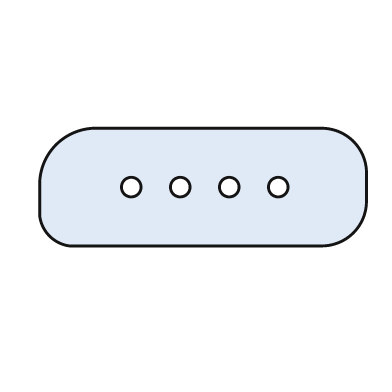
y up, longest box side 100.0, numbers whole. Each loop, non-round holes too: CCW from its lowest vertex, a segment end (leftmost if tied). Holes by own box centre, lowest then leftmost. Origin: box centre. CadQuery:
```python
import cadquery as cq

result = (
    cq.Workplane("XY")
    .moveTo(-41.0, -18.0)
    .lineTo(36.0, -18.0)
    .threePointArc((46.0, -14.0), (50.0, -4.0))
    .lineTo(50.0, 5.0)
    .threePointArc((46.0, 14.0), (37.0, 18.0))
    .lineTo(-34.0, 18.0)
    .threePointArc((-45.0, 13.0), (-50.0, 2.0))
    .lineTo(-50.0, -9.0)
    .threePointArc((-47.0, -15.0), (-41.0, -18.0))
    .close()
    .moveTo(-22.0, 0.0)
    .circle(3.0)
    .moveTo(-7.0, 0.0)
    .circle(3.0)
    .moveTo(8.0, 0.0)
    .circle(3.0)
    .moveTo(23.0, 0.0)
    .circle(3.0)
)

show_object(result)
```